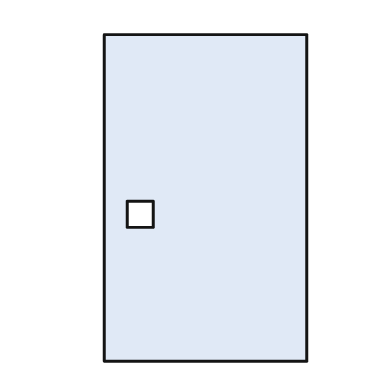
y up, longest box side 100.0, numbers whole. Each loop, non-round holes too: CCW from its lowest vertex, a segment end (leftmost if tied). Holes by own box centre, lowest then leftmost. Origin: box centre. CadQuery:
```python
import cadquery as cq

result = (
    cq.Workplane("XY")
    .moveTo(-31.0, -50.0)
    .lineTo(31.0, -50.0)
    .lineTo(31.0, 50.0)
    .lineTo(-31.0, 50.0)
    .close()
    .moveTo(-24.0, -9.0)
    .lineTo(-16.0, -9.0)
    .lineTo(-16.0, -1.0)
    .lineTo(-24.0, -1.0)
    .close()
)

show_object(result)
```